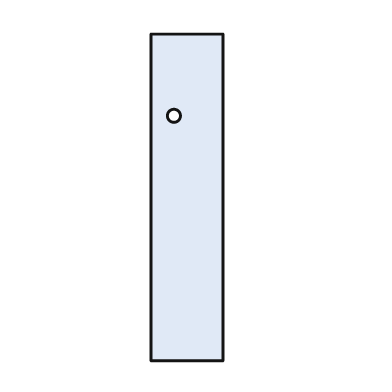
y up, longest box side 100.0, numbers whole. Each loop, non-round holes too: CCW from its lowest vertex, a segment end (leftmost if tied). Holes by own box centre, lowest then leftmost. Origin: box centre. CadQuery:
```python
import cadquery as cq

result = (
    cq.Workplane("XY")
    .moveTo(-11.0, -50.0)
    .lineTo(11.0, -50.0)
    .lineTo(11.0, 50.0)
    .lineTo(-11.0, 50.0)
    .close()
    .moveTo(-4.0, 25.0)
    .circle(2.0)
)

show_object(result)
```